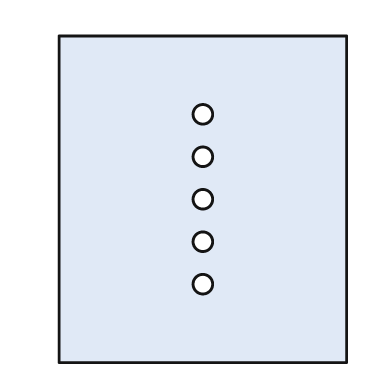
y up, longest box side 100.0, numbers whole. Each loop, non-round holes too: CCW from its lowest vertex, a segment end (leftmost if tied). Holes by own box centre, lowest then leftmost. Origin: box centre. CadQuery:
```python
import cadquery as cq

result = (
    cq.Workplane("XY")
    .moveTo(-44.0, -50.0)
    .lineTo(44.0, -50.0)
    .lineTo(44.0, 50.0)
    .lineTo(-44.0, 50.0)
    .close()
    .moveTo(0.0, -26.0)
    .circle(3.0)
    .moveTo(0.0, -13.0)
    .circle(3.0)
    .moveTo(0.0, 0.0)
    .circle(3.0)
    .moveTo(0.0, 13.0)
    .circle(3.0)
    .moveTo(0.0, 26.0)
    .circle(3.0)
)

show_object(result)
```